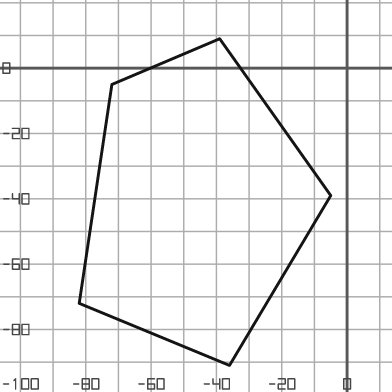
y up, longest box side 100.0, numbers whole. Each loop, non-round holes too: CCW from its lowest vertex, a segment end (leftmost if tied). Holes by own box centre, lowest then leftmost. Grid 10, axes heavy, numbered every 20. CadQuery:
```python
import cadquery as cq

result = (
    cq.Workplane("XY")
    .moveTo(-36.0, -91.0)
    .lineTo(-5.0, -39.0)
    .lineTo(-39.0, 9.0)
    .lineTo(-72.0, -5.0)
    .lineTo(-82.0, -72.0)
    .close()
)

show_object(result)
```